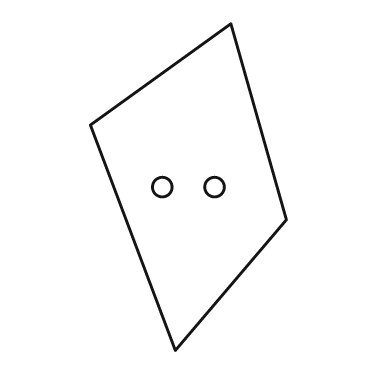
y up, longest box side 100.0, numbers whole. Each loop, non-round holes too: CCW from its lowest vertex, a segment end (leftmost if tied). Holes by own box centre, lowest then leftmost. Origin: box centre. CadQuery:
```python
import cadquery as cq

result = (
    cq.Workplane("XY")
    .moveTo(-4.0, -50.0)
    .lineTo(30.0, -10.0)
    .lineTo(13.0, 50.0)
    .lineTo(-30.0, 19.0)
    .close()
    .moveTo(-8.0, 0.0)
    .circle(3.0)
    .moveTo(8.0, 0.0)
    .circle(3.0)
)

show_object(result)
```